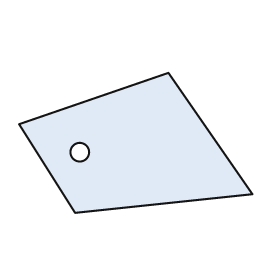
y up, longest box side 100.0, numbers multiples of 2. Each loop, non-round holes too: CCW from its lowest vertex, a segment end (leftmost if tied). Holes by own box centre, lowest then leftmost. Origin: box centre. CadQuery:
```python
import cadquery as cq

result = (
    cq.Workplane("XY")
    .moveTo(-26.0, -30.0)
    .lineTo(50.0, -22.0)
    .lineTo(14.0, 30.0)
    .lineTo(-50.0, 8.0)
    .close()
    .moveTo(-24.0, -4.0)
    .circle(4.0)
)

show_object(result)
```